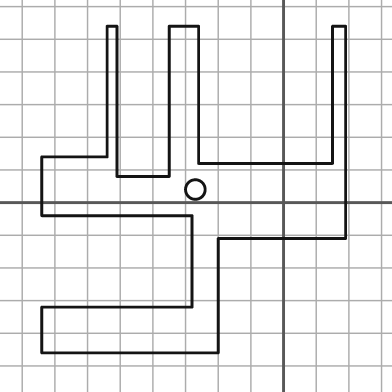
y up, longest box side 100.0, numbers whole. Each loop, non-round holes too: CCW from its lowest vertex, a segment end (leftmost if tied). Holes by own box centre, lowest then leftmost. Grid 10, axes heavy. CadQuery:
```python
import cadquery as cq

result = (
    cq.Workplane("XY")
    .moveTo(-74.0, -46.0)
    .lineTo(-20.0, -46.0)
    .lineTo(-20.0, -11.0)
    .lineTo(19.0, -11.0)
    .lineTo(19.0, 54.0)
    .lineTo(15.0, 54.0)
    .lineTo(15.0, 12.0)
    .lineTo(-26.0, 12.0)
    .lineTo(-26.0, 54.0)
    .lineTo(-35.0, 54.0)
    .lineTo(-35.0, 8.0)
    .lineTo(-51.0, 8.0)
    .lineTo(-51.0, 54.0)
    .lineTo(-54.0, 54.0)
    .lineTo(-54.0, 14.0)
    .lineTo(-74.0, 14.0)
    .lineTo(-74.0, -4.0)
    .lineTo(-28.0, -4.0)
    .lineTo(-28.0, -32.0)
    .lineTo(-74.0, -32.0)
    .close()
    .moveTo(-27.0, 4.0)
    .circle(3.0)
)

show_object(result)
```